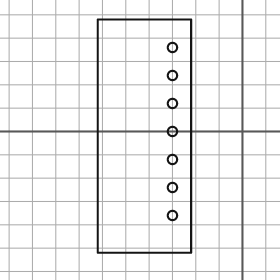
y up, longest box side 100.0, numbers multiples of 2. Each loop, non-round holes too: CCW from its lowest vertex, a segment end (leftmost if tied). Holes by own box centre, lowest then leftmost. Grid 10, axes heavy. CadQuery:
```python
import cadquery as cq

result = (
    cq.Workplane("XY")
    .moveTo(-62.0, -52.0)
    .lineTo(-22.0, -52.0)
    .lineTo(-22.0, 48.0)
    .lineTo(-62.0, 48.0)
    .close()
    .moveTo(-30.0, -36.0)
    .circle(2.0)
    .moveTo(-30.0, -24.0)
    .circle(2.0)
    .moveTo(-30.0, -12.0)
    .circle(2.0)
    .moveTo(-30.0, 0.0)
    .circle(2.0)
    .moveTo(-30.0, 12.0)
    .circle(2.0)
    .moveTo(-30.0, 24.0)
    .circle(2.0)
    .moveTo(-30.0, 36.0)
    .circle(2.0)
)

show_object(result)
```